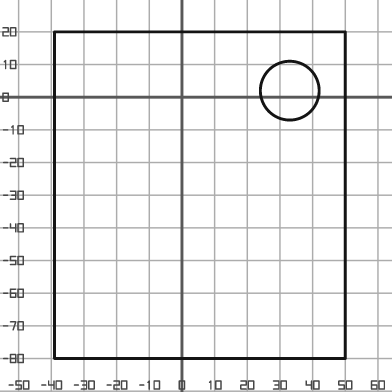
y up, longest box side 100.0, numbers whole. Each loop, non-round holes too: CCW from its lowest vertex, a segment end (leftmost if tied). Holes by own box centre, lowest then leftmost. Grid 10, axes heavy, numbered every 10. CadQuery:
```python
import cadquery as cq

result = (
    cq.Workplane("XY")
    .moveTo(-39.0, -80.0)
    .lineTo(50.0, -80.0)
    .lineTo(50.0, 20.0)
    .lineTo(-39.0, 20.0)
    .close()
    .moveTo(33.0, 2.0)
    .circle(9.0)
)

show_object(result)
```